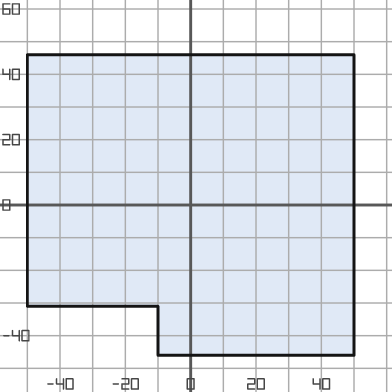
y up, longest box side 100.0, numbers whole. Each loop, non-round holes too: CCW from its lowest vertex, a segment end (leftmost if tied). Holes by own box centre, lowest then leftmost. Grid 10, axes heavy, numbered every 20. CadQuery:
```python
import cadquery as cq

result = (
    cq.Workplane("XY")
    .moveTo(-10.0, -46.0)
    .lineTo(50.0, -46.0)
    .lineTo(50.0, 46.0)
    .lineTo(-50.0, 46.0)
    .lineTo(-50.0, -31.0)
    .lineTo(-10.0, -31.0)
    .close()
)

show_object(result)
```